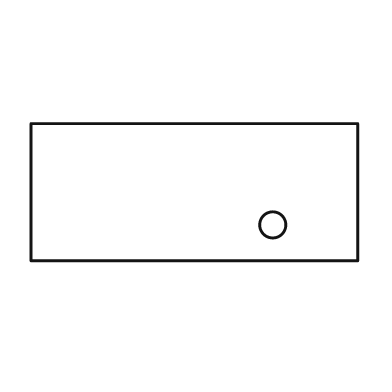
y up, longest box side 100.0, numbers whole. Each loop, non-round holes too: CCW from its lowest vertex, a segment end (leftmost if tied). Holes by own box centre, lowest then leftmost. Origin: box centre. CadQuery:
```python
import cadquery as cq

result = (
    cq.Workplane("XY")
    .moveTo(-50.0, -21.0)
    .lineTo(50.0, -21.0)
    .lineTo(50.0, 21.0)
    .lineTo(-50.0, 21.0)
    .close()
    .moveTo(24.0, -10.0)
    .circle(4.0)
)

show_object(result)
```